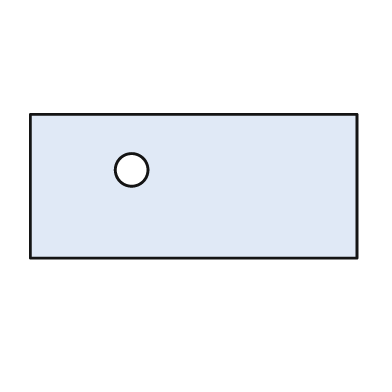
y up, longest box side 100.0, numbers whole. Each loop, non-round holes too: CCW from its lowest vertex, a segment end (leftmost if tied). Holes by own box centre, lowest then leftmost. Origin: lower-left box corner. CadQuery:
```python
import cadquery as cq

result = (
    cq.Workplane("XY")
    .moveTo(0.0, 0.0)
    .lineTo(100.0, 0.0)
    .lineTo(100.0, 44.0)
    .lineTo(0.0, 44.0)
    .close()
    .moveTo(31.0, 27.0)
    .circle(5.0)
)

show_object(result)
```